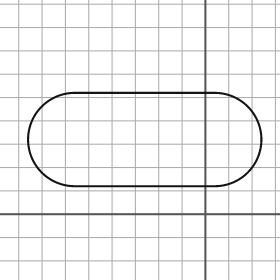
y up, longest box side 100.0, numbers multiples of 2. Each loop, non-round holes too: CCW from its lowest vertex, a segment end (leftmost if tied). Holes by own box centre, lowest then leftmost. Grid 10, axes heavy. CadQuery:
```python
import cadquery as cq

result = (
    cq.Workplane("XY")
    .moveTo(-56.0, 12.0)
    .lineTo(4.0, 12.0)
    .threePointArc((24.0, 32.0), (4.0, 52.0))
    .lineTo(-56.0, 52.0)
    .threePointArc((-76.0, 32.0), (-56.0, 12.0))
    .close()
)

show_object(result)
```